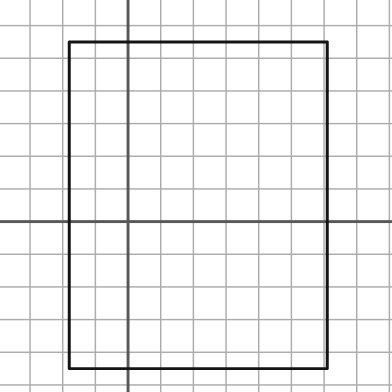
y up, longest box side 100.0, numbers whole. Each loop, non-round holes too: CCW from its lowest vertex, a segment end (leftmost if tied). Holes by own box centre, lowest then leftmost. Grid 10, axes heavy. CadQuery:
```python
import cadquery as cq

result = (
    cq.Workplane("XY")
    .moveTo(-18.0, -45.0)
    .lineTo(61.0, -45.0)
    .lineTo(61.0, 55.0)
    .lineTo(-18.0, 55.0)
    .close()
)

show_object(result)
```